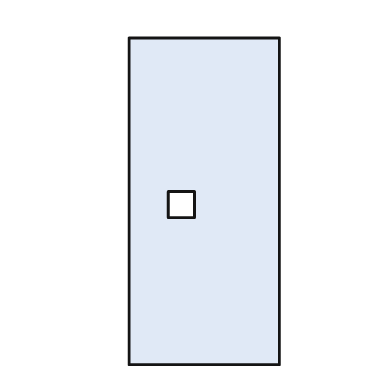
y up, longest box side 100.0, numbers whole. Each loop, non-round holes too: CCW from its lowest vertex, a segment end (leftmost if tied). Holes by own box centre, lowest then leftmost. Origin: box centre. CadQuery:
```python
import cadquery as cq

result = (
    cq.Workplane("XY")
    .moveTo(-23.0, -50.0)
    .lineTo(23.0, -50.0)
    .lineTo(23.0, 50.0)
    .lineTo(-23.0, 50.0)
    .close()
    .moveTo(-11.0, -5.0)
    .lineTo(-3.0, -5.0)
    .lineTo(-3.0, 3.0)
    .lineTo(-11.0, 3.0)
    .close()
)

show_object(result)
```